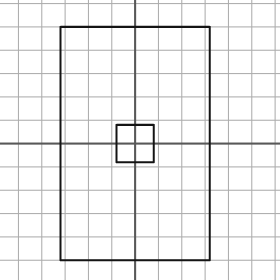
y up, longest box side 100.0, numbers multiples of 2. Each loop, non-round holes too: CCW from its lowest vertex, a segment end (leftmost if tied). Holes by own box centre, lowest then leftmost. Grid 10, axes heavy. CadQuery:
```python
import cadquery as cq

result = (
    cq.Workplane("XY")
    .moveTo(-32.0, -50.0)
    .lineTo(32.0, -50.0)
    .lineTo(32.0, 50.0)
    .lineTo(-32.0, 50.0)
    .close()
    .moveTo(-8.0, -8.0)
    .lineTo(8.0, -8.0)
    .lineTo(8.0, 8.0)
    .lineTo(-8.0, 8.0)
    .close()
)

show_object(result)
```